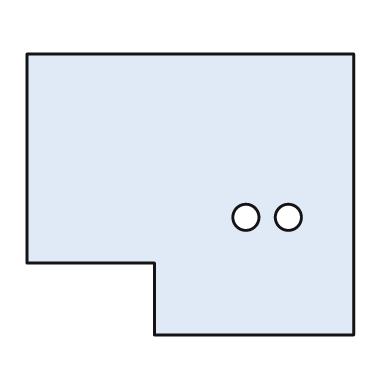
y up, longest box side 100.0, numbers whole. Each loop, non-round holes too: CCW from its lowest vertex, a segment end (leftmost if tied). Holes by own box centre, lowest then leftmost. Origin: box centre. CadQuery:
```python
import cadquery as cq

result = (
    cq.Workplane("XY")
    .moveTo(-11.0, -43.0)
    .lineTo(50.0, -43.0)
    .lineTo(50.0, 43.0)
    .lineTo(-50.0, 43.0)
    .lineTo(-50.0, -21.0)
    .lineTo(-11.0, -21.0)
    .close()
    .moveTo(17.0, -7.0)
    .circle(4.0)
    .moveTo(30.0, -7.0)
    .circle(4.0)
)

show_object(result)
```